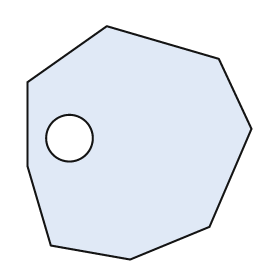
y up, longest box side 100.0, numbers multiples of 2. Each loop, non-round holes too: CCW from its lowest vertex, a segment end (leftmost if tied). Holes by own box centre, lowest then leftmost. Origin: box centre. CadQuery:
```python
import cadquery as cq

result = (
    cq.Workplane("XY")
    .moveTo(-4.0, -50.0)
    .lineTo(30.0, -36.0)
    .lineTo(48.0, 6.0)
    .lineTo(34.0, 36.0)
    .lineTo(-14.0, 50.0)
    .lineTo(-48.0, 26.0)
    .lineTo(-48.0, -10.0)
    .lineTo(-38.0, -44.0)
    .close()
    .moveTo(-30.0, 2.0)
    .circle(10.0)
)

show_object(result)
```